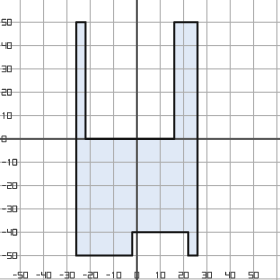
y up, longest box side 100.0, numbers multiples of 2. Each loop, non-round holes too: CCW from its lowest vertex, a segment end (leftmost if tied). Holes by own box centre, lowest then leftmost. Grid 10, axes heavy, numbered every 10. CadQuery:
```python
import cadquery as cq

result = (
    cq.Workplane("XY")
    .moveTo(-26.0, -50.0)
    .lineTo(-2.0, -50.0)
    .lineTo(-2.0, -40.0)
    .lineTo(22.0, -40.0)
    .lineTo(22.0, -50.0)
    .lineTo(26.0, -50.0)
    .lineTo(26.0, 50.0)
    .lineTo(16.0, 50.0)
    .lineTo(16.0, 0.0)
    .lineTo(-22.0, 0.0)
    .lineTo(-22.0, 50.0)
    .lineTo(-26.0, 50.0)
    .close()
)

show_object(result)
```